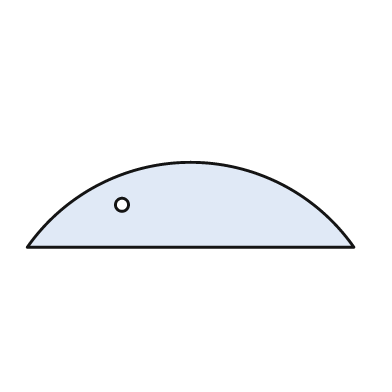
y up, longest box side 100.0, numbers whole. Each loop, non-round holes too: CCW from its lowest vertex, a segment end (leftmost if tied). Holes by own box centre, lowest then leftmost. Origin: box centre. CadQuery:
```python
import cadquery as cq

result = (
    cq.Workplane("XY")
    .moveTo(-50.0, -13.0)
    .lineTo(50.0, -13.0)
    .threePointArc((0.0, 13.0), (-50.0, -13.0))
    .close()
    .moveTo(-21.0, 0.0)
    .circle(2.0)
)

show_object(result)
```